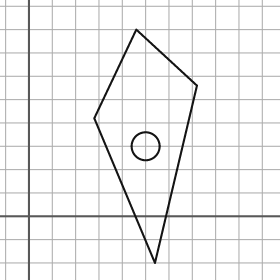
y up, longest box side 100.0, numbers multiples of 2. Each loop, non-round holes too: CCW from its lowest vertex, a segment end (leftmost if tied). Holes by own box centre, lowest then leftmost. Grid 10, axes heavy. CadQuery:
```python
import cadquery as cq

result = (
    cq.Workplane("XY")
    .moveTo(54.0, -20.0)
    .lineTo(72.0, 56.0)
    .lineTo(46.0, 80.0)
    .lineTo(28.0, 42.0)
    .close()
    .moveTo(50.0, 30.0)
    .circle(6.0)
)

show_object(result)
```